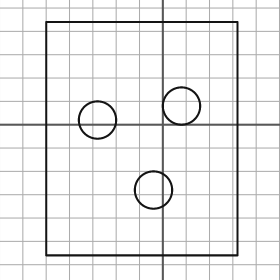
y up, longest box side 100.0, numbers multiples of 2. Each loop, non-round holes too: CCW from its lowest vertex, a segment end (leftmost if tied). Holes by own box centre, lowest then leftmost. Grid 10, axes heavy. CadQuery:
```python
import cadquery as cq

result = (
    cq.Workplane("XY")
    .moveTo(-50.0, -56.0)
    .lineTo(32.0, -56.0)
    .lineTo(32.0, 44.0)
    .lineTo(-50.0, 44.0)
    .close()
    .moveTo(-4.0, -28.0)
    .circle(8.0)
    .moveTo(-28.0, 2.0)
    .circle(8.0)
    .moveTo(8.0, 8.0)
    .circle(8.0)
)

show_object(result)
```